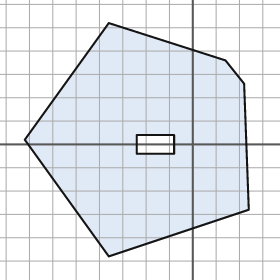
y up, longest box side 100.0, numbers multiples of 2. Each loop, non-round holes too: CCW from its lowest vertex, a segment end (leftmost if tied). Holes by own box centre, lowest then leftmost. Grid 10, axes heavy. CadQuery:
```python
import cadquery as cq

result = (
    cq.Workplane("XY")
    .moveTo(-36.0, -48.0)
    .lineTo(24.0, -28.0)
    .lineTo(22.0, 26.0)
    .lineTo(14.0, 36.0)
    .lineTo(-36.0, 52.0)
    .lineTo(-72.0, 2.0)
    .close()
    .moveTo(-24.0, -4.0)
    .lineTo(-8.0, -4.0)
    .lineTo(-8.0, 4.0)
    .lineTo(-24.0, 4.0)
    .close()
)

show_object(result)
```